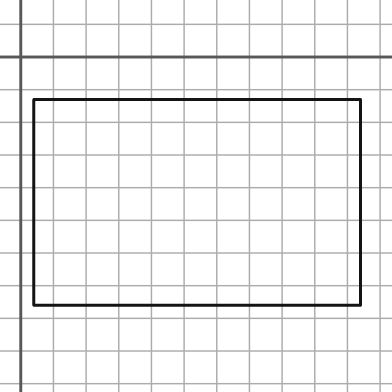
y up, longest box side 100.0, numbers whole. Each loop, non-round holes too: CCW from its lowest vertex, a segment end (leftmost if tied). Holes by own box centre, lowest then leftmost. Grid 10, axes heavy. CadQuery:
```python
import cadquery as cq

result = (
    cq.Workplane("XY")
    .moveTo(4.0, -76.0)
    .lineTo(104.0, -76.0)
    .lineTo(104.0, -13.0)
    .lineTo(4.0, -13.0)
    .close()
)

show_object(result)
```